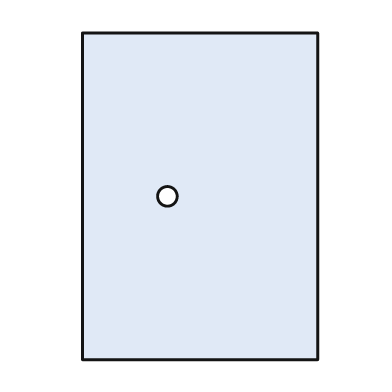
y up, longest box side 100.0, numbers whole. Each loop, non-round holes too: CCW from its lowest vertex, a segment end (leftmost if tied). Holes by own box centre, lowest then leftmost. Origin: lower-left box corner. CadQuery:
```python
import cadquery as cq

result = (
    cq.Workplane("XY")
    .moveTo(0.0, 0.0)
    .lineTo(72.0, 0.0)
    .lineTo(72.0, 100.0)
    .lineTo(0.0, 100.0)
    .close()
    .moveTo(26.0, 50.0)
    .circle(3.0)
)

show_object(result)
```